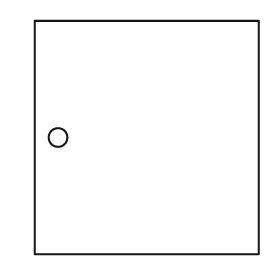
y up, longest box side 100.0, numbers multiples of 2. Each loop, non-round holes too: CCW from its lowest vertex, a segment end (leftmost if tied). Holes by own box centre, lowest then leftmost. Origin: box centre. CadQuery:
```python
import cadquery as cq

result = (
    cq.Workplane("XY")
    .moveTo(-48.0, -50.0)
    .lineTo(48.0, -50.0)
    .lineTo(48.0, 50.0)
    .lineTo(-48.0, 50.0)
    .close()
    .moveTo(-38.0, 0.0)
    .circle(4.0)
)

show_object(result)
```